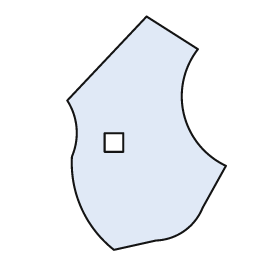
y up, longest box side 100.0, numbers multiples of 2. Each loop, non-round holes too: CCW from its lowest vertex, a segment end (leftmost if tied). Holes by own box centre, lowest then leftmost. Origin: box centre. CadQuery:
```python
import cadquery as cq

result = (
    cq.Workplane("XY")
    .moveTo(-14.0, -50.0)
    .lineTo(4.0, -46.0)
    .threePointArc((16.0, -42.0), (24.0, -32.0))
    .lineTo(34.0, -14.0)
    .threePointArc((16.0, 8.0), (22.0, 36.0))
    .lineTo(0.0, 50.0)
    .lineTo(-34.0, 14.0)
    .threePointArc((-30.0, 2.0), (-32.0, -10.0))
    .threePointArc((-28.0, -32.0), (-14.0, -50.0))
    .close()
    .moveTo(-18.0, -8.0)
    .lineTo(-10.0, -8.0)
    .lineTo(-10.0, 0.0)
    .lineTo(-18.0, 0.0)
    .close()
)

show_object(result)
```